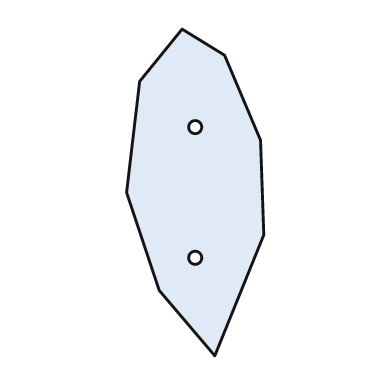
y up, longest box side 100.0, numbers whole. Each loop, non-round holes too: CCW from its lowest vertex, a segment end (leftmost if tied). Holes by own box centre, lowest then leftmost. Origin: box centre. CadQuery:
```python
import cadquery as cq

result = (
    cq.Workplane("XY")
    .moveTo(6.0, -50.0)
    .lineTo(21.0, -13.0)
    .lineTo(20.0, 16.0)
    .lineTo(9.0, 42.0)
    .lineTo(-4.0, 50.0)
    .lineTo(-17.0, 34.0)
    .lineTo(-21.0, 0.0)
    .lineTo(-11.0, -30.0)
    .close()
    .moveTo(0.0, -20.0)
    .circle(2.0)
    .moveTo(0.0, 20.0)
    .circle(2.0)
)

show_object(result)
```